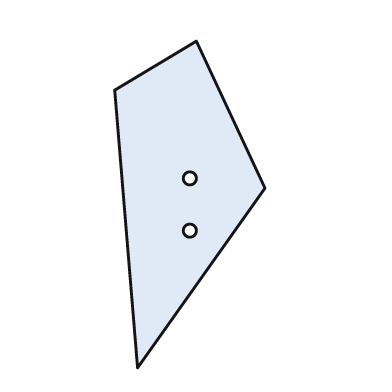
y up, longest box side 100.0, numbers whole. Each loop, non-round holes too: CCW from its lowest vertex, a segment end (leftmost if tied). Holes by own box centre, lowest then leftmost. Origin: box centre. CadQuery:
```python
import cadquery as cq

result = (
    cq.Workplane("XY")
    .moveTo(-16.0, -50.0)
    .lineTo(23.0, 5.0)
    .lineTo(2.0, 50.0)
    .lineTo(-23.0, 35.0)
    .close()
    .moveTo(0.0, -8.0)
    .circle(2.0)
    .moveTo(0.0, 8.0)
    .circle(2.0)
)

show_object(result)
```